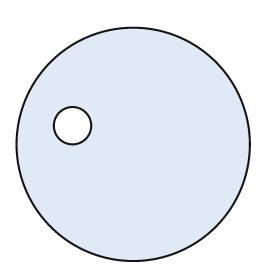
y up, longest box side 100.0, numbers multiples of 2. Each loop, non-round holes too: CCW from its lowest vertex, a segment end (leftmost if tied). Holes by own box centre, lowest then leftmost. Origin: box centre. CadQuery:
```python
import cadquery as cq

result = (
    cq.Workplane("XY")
    .moveTo(0.0, 0.0)
    .circle(50.0)
    .moveTo(-26.0, 8.0)
    .circle(8.0)
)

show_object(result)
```